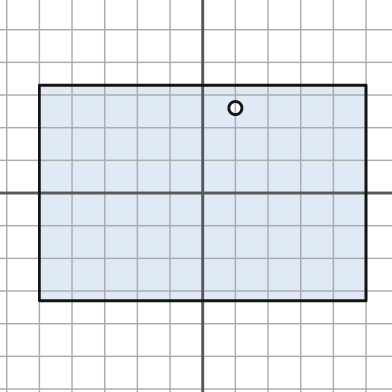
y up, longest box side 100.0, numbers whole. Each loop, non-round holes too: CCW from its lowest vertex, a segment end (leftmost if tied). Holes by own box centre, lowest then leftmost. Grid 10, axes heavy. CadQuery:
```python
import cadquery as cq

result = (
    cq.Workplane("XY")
    .moveTo(-50.0, -33.0)
    .lineTo(50.0, -33.0)
    .lineTo(50.0, 33.0)
    .lineTo(-50.0, 33.0)
    .close()
    .moveTo(10.0, 26.0)
    .circle(2.0)
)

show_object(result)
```